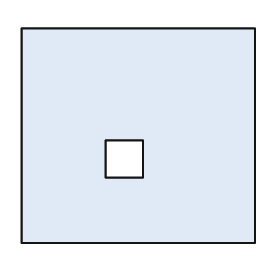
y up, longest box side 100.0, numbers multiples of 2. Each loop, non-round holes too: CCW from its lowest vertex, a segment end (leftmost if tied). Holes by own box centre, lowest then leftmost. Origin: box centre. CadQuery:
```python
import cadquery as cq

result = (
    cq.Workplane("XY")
    .moveTo(-50.0, -46.0)
    .lineTo(50.0, -46.0)
    .lineTo(50.0, 46.0)
    .lineTo(-50.0, 46.0)
    .close()
    .moveTo(-14.0, -18.0)
    .lineTo(2.0, -18.0)
    .lineTo(2.0, -2.0)
    .lineTo(-14.0, -2.0)
    .close()
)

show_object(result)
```